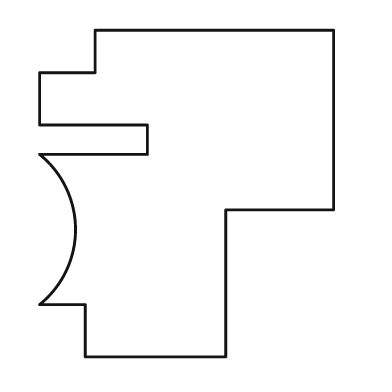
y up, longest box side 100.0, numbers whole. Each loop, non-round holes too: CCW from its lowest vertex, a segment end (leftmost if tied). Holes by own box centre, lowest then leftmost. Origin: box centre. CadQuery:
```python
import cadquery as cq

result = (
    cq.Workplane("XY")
    .moveTo(-31.0, -50.0)
    .lineTo(12.0, -50.0)
    .lineTo(12.0, -5.0)
    .lineTo(45.0, -5.0)
    .lineTo(45.0, 50.0)
    .lineTo(-28.0, 50.0)
    .lineTo(-28.0, 37.0)
    .lineTo(-45.0, 37.0)
    .lineTo(-45.0, 21.0)
    .lineTo(-12.0, 21.0)
    .lineTo(-12.0, 12.0)
    .lineTo(-45.0, 12.0)
    .threePointArc((-34.0, -11.0), (-45.0, -34.0))
    .lineTo(-31.0, -34.0)
    .close()
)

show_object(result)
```